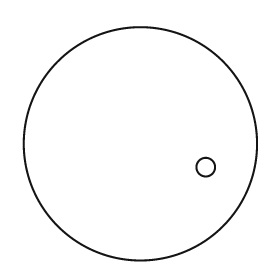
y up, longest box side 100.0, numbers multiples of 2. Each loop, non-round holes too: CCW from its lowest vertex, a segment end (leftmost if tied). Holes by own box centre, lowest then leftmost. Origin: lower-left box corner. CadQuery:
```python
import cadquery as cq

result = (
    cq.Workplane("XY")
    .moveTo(50.0, 50.0)
    .circle(50.0)
    .moveTo(78.0, 40.0)
    .circle(4.0)
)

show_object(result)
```